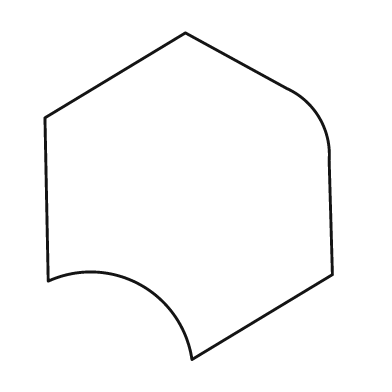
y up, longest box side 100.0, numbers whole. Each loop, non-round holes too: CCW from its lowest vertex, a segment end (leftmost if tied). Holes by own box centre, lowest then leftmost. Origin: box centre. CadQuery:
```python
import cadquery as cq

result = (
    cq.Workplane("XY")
    .moveTo(1.0, -50.0)
    .lineTo(44.0, -24.0)
    .lineTo(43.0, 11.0)
    .threePointArc((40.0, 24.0), (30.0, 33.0))
    .lineTo(-1.0, 50.0)
    .lineTo(-44.0, 24.0)
    .lineTo(-43.0, -26.0)
    .threePointArc((-15.0, -27.0), (1.0, -50.0))
    .close()
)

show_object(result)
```